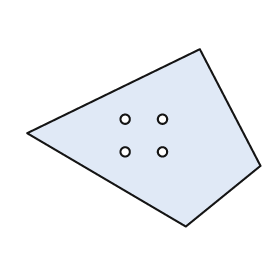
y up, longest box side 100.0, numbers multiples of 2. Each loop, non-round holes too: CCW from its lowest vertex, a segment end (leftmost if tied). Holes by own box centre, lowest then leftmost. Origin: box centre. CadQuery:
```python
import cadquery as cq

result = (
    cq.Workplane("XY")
    .moveTo(18.0, -38.0)
    .lineTo(50.0, -12.0)
    .lineTo(24.0, 38.0)
    .lineTo(-50.0, 2.0)
    .close()
    .moveTo(-8.0, -6.0)
    .circle(2.0)
    .moveTo(8.0, -6.0)
    .circle(2.0)
    .moveTo(-8.0, 8.0)
    .circle(2.0)
    .moveTo(8.0, 8.0)
    .circle(2.0)
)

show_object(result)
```